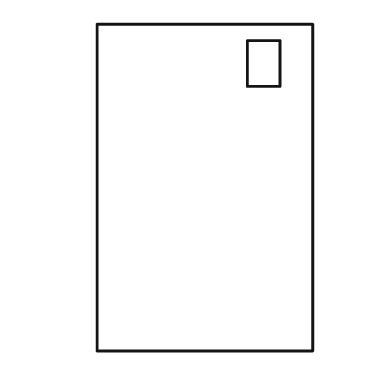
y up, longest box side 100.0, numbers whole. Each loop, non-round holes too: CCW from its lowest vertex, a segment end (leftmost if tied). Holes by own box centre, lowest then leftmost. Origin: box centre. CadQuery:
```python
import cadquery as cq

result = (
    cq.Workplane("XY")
    .moveTo(-33.0, -50.0)
    .lineTo(33.0, -50.0)
    .lineTo(33.0, 50.0)
    .lineTo(-33.0, 50.0)
    .close()
    .moveTo(13.0, 31.0)
    .lineTo(23.0, 31.0)
    .lineTo(23.0, 45.0)
    .lineTo(13.0, 45.0)
    .close()
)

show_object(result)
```